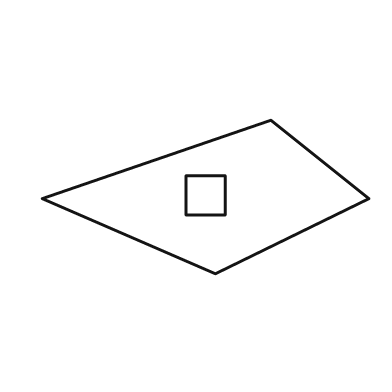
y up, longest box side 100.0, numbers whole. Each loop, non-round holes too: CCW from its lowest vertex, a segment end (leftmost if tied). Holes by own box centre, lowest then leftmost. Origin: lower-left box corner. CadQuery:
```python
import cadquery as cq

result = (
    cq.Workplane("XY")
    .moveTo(53.0, 0.0)
    .lineTo(100.0, 23.0)
    .lineTo(70.0, 47.0)
    .lineTo(0.0, 23.0)
    .close()
    .moveTo(44.0, 18.0)
    .lineTo(56.0, 18.0)
    .lineTo(56.0, 30.0)
    .lineTo(44.0, 30.0)
    .close()
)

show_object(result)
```